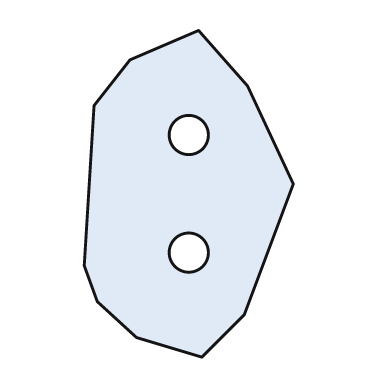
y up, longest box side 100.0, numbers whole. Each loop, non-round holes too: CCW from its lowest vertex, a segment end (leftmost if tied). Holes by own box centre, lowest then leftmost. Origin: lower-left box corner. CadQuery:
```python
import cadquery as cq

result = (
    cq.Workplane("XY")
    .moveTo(36.0, 0.0)
    .lineTo(49.0, 13.0)
    .lineTo(64.0, 53.0)
    .lineTo(50.0, 83.0)
    .lineTo(35.0, 100.0)
    .lineTo(14.0, 91.0)
    .lineTo(3.0, 77.0)
    .lineTo(0.0, 28.0)
    .lineTo(4.0, 17.0)
    .lineTo(16.0, 6.0)
    .close()
    .moveTo(32.0, 32.0)
    .circle(6.0)
    .moveTo(32.0, 68.0)
    .circle(6.0)
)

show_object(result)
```